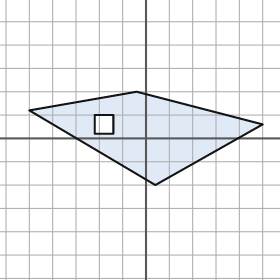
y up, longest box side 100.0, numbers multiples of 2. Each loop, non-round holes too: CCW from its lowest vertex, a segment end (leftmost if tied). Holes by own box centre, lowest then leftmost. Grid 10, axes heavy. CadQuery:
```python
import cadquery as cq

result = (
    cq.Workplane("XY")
    .moveTo(4.0, -20.0)
    .lineTo(50.0, 6.0)
    .lineTo(-4.0, 20.0)
    .lineTo(-50.0, 12.0)
    .close()
    .moveTo(-22.0, 2.0)
    .lineTo(-14.0, 2.0)
    .lineTo(-14.0, 10.0)
    .lineTo(-22.0, 10.0)
    .close()
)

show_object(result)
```